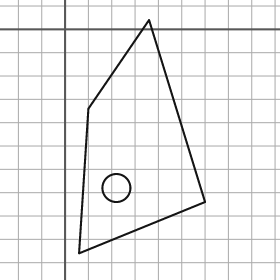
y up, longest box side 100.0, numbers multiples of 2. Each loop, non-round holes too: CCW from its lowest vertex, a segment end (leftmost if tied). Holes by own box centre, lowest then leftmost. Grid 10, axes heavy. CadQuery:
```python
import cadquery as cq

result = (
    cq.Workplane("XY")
    .moveTo(6.0, -96.0)
    .lineTo(60.0, -74.0)
    .lineTo(36.0, 4.0)
    .lineTo(10.0, -34.0)
    .close()
    .moveTo(22.0, -68.0)
    .circle(6.0)
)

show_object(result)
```